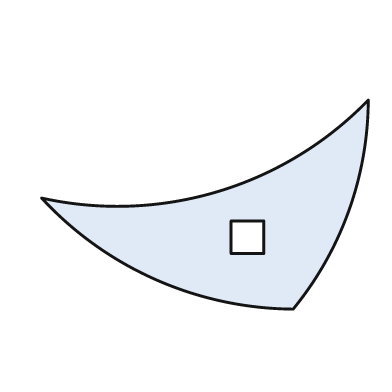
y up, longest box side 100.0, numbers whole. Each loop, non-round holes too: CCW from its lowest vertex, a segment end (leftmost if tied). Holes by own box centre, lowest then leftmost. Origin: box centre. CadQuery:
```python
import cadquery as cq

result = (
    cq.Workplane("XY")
    .moveTo(27.0, -32.0)
    .threePointArc((44.0, -2.0), (50.0, 32.0))
    .threePointArc((4.0, 4.0), (-50.0, 2.0))
    .threePointArc((-15.0, -23.0), (27.0, -32.0))
    .close()
    .moveTo(8.0, -15.0)
    .lineTo(18.0, -15.0)
    .lineTo(18.0, -5.0)
    .lineTo(8.0, -5.0)
    .close()
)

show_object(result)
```